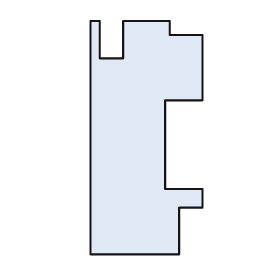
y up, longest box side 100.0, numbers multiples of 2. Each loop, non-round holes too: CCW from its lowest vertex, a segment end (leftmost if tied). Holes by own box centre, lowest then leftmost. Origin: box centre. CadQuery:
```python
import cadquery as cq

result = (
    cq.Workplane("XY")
    .moveTo(-24.0, -50.0)
    .lineTo(14.0, -50.0)
    .lineTo(14.0, -30.0)
    .lineTo(24.0, -30.0)
    .lineTo(24.0, -22.0)
    .lineTo(8.0, -22.0)
    .lineTo(8.0, 16.0)
    .lineTo(24.0, 16.0)
    .lineTo(24.0, 44.0)
    .lineTo(10.0, 44.0)
    .lineTo(10.0, 50.0)
    .lineTo(-10.0, 50.0)
    .lineTo(-10.0, 34.0)
    .lineTo(-20.0, 34.0)
    .lineTo(-20.0, 50.0)
    .lineTo(-24.0, 50.0)
    .close()
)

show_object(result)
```